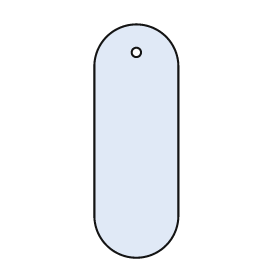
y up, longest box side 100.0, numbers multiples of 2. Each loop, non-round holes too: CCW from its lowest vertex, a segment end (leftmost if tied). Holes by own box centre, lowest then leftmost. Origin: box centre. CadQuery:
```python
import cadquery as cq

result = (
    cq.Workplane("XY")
    .moveTo(-18.0, -32.0)
    .threePointArc((0.0, -50.0), (18.0, -32.0))
    .lineTo(18.0, 32.0)
    .threePointArc((0.0, 50.0), (-18.0, 32.0))
    .close()
    .moveTo(0.0, 38.0)
    .circle(2.0)
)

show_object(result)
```